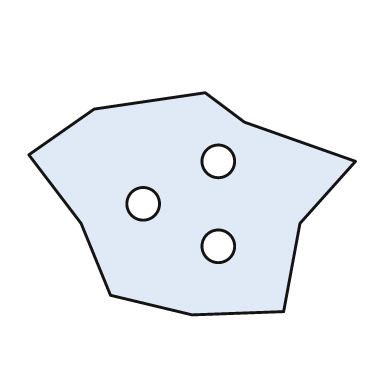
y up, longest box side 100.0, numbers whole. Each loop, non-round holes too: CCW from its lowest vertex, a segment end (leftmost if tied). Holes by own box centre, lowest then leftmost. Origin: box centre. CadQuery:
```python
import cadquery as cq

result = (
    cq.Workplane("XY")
    .moveTo(0.0, -34.0)
    .lineTo(28.0, -33.0)
    .lineTo(33.0, -6.0)
    .lineTo(50.0, 13.0)
    .lineTo(16.0, 25.0)
    .lineTo(4.0, 34.0)
    .lineTo(-30.0, 29.0)
    .lineTo(-50.0, 15.0)
    .lineTo(-34.0, -6.0)
    .lineTo(-25.0, -28.0)
    .close()
    .moveTo(8.0, -13.0)
    .circle(5.0)
    .moveTo(-15.0, 0.0)
    .circle(5.0)
    .moveTo(8.0, 13.0)
    .circle(5.0)
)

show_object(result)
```